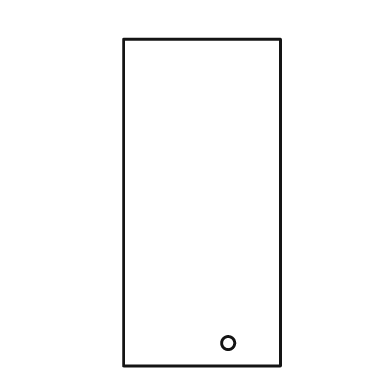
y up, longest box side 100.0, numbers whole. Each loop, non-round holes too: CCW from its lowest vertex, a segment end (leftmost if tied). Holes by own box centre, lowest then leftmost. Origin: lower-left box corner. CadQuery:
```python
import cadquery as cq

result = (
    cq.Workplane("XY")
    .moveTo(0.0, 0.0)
    .lineTo(48.0, 0.0)
    .lineTo(48.0, 100.0)
    .lineTo(0.0, 100.0)
    .close()
    .moveTo(32.0, 7.0)
    .circle(2.0)
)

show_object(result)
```